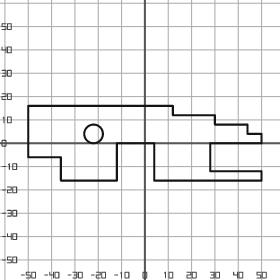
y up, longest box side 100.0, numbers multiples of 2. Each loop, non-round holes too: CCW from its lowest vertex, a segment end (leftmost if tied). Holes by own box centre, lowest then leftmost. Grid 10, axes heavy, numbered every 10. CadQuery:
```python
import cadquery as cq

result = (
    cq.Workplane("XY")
    .moveTo(-36.0, -16.0)
    .lineTo(-12.0, -16.0)
    .lineTo(-12.0, 0.0)
    .lineTo(4.0, 0.0)
    .lineTo(4.0, -16.0)
    .lineTo(50.0, -16.0)
    .lineTo(50.0, -12.0)
    .lineTo(28.0, -12.0)
    .lineTo(28.0, 0.0)
    .lineTo(50.0, 0.0)
    .lineTo(50.0, 4.0)
    .lineTo(44.0, 4.0)
    .lineTo(44.0, 8.0)
    .lineTo(30.0, 8.0)
    .lineTo(30.0, 12.0)
    .lineTo(12.0, 12.0)
    .lineTo(12.0, 16.0)
    .lineTo(-50.0, 16.0)
    .lineTo(-50.0, -6.0)
    .lineTo(-36.0, -6.0)
    .close()
    .moveTo(-22.0, 4.0)
    .circle(4.0)
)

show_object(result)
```